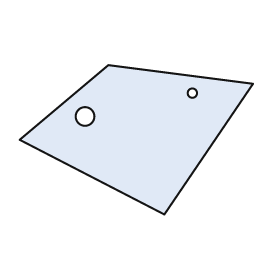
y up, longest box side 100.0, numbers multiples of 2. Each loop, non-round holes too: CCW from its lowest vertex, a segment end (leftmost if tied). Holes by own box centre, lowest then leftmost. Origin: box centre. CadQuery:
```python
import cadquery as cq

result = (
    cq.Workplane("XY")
    .moveTo(12.0, -32.0)
    .lineTo(50.0, 24.0)
    .lineTo(-12.0, 32.0)
    .lineTo(-50.0, 0.0)
    .close()
    .moveTo(-22.0, 10.0)
    .circle(4.0)
    .moveTo(24.0, 20.0)
    .circle(2.0)
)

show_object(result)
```